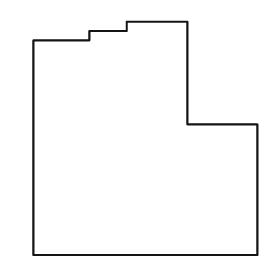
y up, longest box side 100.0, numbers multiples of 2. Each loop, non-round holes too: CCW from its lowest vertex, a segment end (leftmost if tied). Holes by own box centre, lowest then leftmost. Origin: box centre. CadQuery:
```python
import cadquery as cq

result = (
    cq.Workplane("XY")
    .moveTo(-48.0, -50.0)
    .lineTo(48.0, -50.0)
    .lineTo(48.0, 6.0)
    .lineTo(18.0, 6.0)
    .lineTo(18.0, 50.0)
    .lineTo(-8.0, 50.0)
    .lineTo(-8.0, 46.0)
    .lineTo(-24.0, 46.0)
    .lineTo(-24.0, 42.0)
    .lineTo(-48.0, 42.0)
    .close()
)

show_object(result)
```